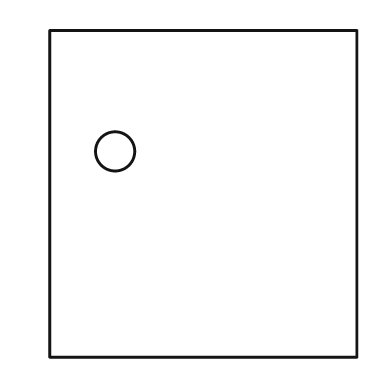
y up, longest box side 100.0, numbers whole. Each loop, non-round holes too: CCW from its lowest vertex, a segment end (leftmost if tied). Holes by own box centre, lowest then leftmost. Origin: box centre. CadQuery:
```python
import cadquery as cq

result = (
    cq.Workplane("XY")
    .moveTo(-47.0, -50.0)
    .lineTo(47.0, -50.0)
    .lineTo(47.0, 50.0)
    .lineTo(-47.0, 50.0)
    .close()
    .moveTo(-27.0, 13.0)
    .circle(6.0)
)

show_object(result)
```